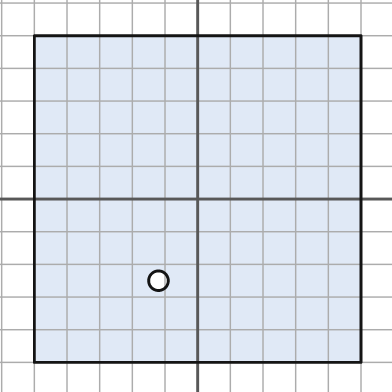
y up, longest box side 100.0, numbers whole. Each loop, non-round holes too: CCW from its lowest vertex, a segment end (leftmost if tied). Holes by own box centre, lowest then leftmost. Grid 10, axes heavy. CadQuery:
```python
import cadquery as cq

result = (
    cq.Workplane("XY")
    .moveTo(-50.0, -50.0)
    .lineTo(50.0, -50.0)
    .lineTo(50.0, 50.0)
    .lineTo(-50.0, 50.0)
    .close()
    .moveTo(-12.0, -25.0)
    .circle(3.0)
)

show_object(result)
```